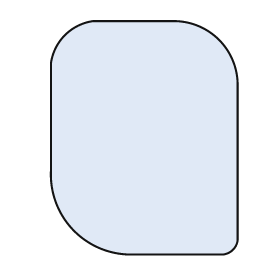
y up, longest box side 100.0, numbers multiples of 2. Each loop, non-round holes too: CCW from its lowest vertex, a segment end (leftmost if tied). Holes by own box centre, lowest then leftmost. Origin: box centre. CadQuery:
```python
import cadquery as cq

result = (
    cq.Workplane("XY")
    .moveTo(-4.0, -50.0)
    .lineTo(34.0, -50.0)
    .threePointArc((38.0, -48.0), (40.0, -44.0))
    .lineTo(40.0, 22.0)
    .threePointArc((32.0, 42.0), (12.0, 50.0))
    .lineTo(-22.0, 50.0)
    .threePointArc((-34.0, 44.0), (-40.0, 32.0))
    .lineTo(-40.0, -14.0)
    .threePointArc((-30.0, -40.0), (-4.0, -50.0))
    .close()
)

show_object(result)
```